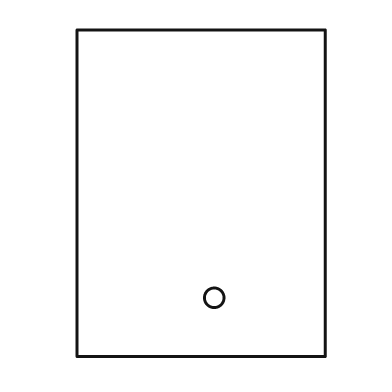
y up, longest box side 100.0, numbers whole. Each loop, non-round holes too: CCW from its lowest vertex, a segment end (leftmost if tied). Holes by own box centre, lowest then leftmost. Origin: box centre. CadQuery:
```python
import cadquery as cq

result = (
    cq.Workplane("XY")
    .moveTo(-38.0, -50.0)
    .lineTo(38.0, -50.0)
    .lineTo(38.0, 50.0)
    .lineTo(-38.0, 50.0)
    .close()
    .moveTo(4.0, -32.0)
    .circle(3.0)
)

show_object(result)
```